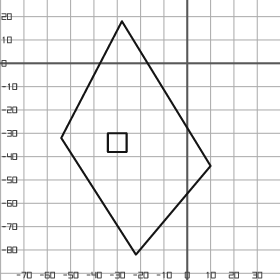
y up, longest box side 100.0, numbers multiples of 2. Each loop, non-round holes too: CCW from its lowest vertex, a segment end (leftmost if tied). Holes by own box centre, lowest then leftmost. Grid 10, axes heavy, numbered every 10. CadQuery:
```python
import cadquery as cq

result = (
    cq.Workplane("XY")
    .moveTo(-22.0, -82.0)
    .lineTo(10.0, -44.0)
    .lineTo(-28.0, 18.0)
    .lineTo(-54.0, -32.0)
    .close()
    .moveTo(-34.0, -38.0)
    .lineTo(-26.0, -38.0)
    .lineTo(-26.0, -30.0)
    .lineTo(-34.0, -30.0)
    .close()
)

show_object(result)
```